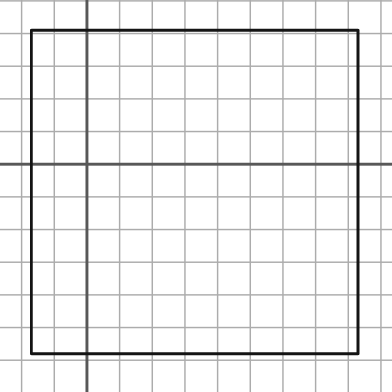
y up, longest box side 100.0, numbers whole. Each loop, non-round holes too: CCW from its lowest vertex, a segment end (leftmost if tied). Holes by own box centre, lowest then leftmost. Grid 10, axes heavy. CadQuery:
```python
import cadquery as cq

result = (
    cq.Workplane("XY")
    .moveTo(-17.0, -58.0)
    .lineTo(83.0, -58.0)
    .lineTo(83.0, 41.0)
    .lineTo(-17.0, 41.0)
    .close()
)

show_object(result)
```